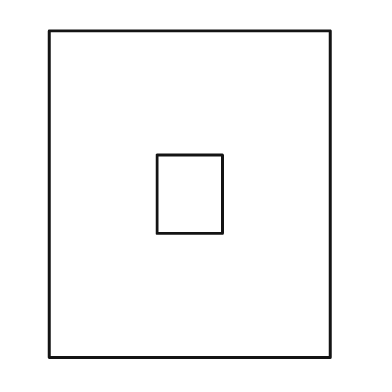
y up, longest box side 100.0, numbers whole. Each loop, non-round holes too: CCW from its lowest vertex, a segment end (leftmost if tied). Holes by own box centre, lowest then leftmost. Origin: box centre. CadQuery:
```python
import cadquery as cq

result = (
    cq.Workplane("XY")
    .moveTo(-43.0, -50.0)
    .lineTo(43.0, -50.0)
    .lineTo(43.0, 50.0)
    .lineTo(-43.0, 50.0)
    .close()
    .moveTo(-10.0, -12.0)
    .lineTo(10.0, -12.0)
    .lineTo(10.0, 12.0)
    .lineTo(-10.0, 12.0)
    .close()
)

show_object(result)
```